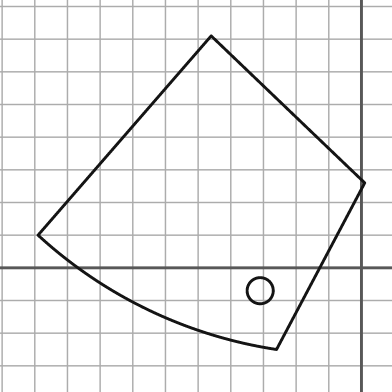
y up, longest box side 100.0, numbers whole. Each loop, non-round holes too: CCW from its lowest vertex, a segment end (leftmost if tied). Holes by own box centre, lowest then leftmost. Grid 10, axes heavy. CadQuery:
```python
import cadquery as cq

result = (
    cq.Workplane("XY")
    .moveTo(-26.0, -25.0)
    .lineTo(1.0, 26.0)
    .lineTo(-46.0, 71.0)
    .lineTo(-99.0, 10.0)
    .threePointArc((-65.0, -13.0), (-26.0, -25.0))
    .close()
    .moveTo(-31.0, -7.0)
    .circle(4.0)
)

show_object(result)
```